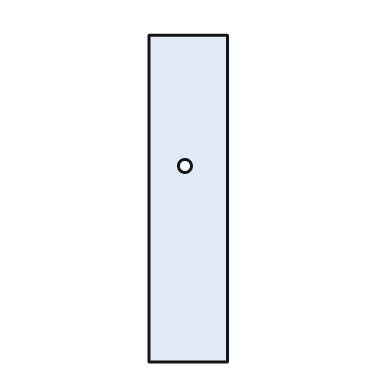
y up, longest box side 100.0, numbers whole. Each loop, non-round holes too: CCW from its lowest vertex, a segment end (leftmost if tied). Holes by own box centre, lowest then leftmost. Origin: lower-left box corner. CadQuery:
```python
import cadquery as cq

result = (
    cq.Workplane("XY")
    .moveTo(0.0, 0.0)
    .lineTo(24.0, 0.0)
    .lineTo(24.0, 100.0)
    .lineTo(0.0, 100.0)
    .close()
    .moveTo(11.0, 60.0)
    .circle(2.0)
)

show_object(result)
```